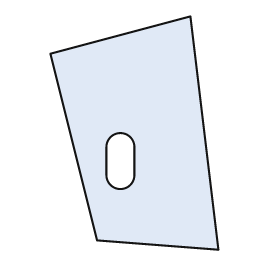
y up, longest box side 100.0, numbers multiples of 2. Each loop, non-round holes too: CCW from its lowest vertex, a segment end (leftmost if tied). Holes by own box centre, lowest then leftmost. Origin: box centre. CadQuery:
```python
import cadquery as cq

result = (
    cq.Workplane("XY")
    .moveTo(36.0, -50.0)
    .lineTo(24.0, 50.0)
    .lineTo(-36.0, 34.0)
    .lineTo(-16.0, -46.0)
    .close()
    .moveTo(-12.0, -18.0)
    .threePointArc((-6.0, -24.0), (0.0, -18.0))
    .lineTo(0.0, -6.0)
    .threePointArc((-6.0, 0.0), (-12.0, -6.0))
    .close()
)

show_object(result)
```